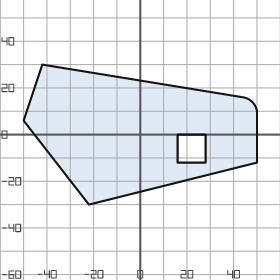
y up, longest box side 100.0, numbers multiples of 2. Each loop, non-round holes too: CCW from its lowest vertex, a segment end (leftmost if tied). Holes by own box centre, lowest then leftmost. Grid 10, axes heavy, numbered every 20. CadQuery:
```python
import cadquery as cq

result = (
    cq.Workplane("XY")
    .moveTo(-22.0, -30.0)
    .lineTo(50.0, -12.0)
    .lineTo(50.0, 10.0)
    .threePointArc((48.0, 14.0), (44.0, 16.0))
    .lineTo(-42.0, 30.0)
    .lineTo(-50.0, 6.0)
    .close()
    .moveTo(16.0, -12.0)
    .lineTo(28.0, -12.0)
    .lineTo(28.0, 0.0)
    .lineTo(16.0, 0.0)
    .close()
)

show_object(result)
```